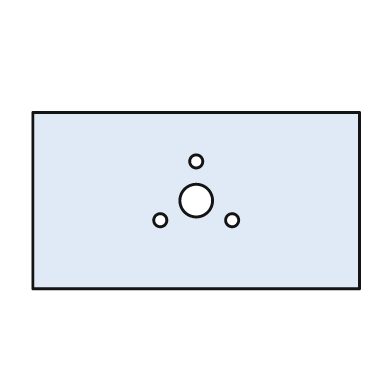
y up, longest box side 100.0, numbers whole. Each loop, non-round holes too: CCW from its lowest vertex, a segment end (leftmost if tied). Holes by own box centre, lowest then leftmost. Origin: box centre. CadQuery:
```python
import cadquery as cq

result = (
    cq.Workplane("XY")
    .moveTo(-50.0, -27.0)
    .lineTo(50.0, -27.0)
    .lineTo(50.0, 27.0)
    .lineTo(-50.0, 27.0)
    .close()
    .moveTo(-11.0, -6.0)
    .circle(2.0)
    .moveTo(11.0, -6.0)
    .circle(2.0)
    .moveTo(0.0, 0.0)
    .circle(5.0)
    .moveTo(0.0, 12.0)
    .circle(2.0)
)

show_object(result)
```